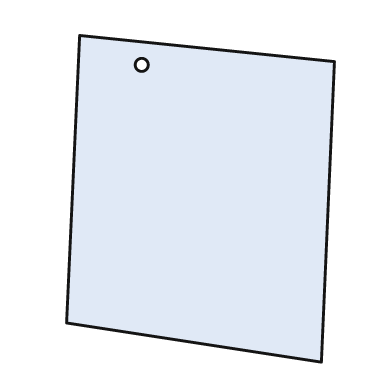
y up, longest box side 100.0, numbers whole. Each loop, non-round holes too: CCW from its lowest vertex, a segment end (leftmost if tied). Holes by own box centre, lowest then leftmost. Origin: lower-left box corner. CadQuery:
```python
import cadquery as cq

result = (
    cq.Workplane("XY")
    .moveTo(78.0, 0.0)
    .lineTo(82.0, 92.0)
    .lineTo(4.0, 100.0)
    .lineTo(0.0, 12.0)
    .close()
    .moveTo(23.0, 91.0)
    .circle(2.0)
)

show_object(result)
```